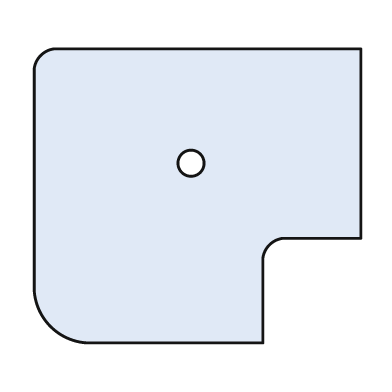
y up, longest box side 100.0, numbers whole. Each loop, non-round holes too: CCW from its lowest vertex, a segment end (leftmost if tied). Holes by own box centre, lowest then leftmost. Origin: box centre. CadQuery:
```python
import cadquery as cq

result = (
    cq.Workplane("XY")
    .moveTo(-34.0, -45.0)
    .lineTo(20.0, -45.0)
    .lineTo(20.0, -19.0)
    .threePointArc((22.0, -15.0), (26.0, -13.0))
    .lineTo(50.0, -13.0)
    .lineTo(50.0, 45.0)
    .lineTo(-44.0, 45.0)
    .threePointArc((-48.0, 43.0), (-50.0, 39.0))
    .lineTo(-50.0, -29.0)
    .threePointArc((-45.0, -40.0), (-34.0, -45.0))
    .close()
    .moveTo(-2.0, 10.0)
    .circle(4.0)
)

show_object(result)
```